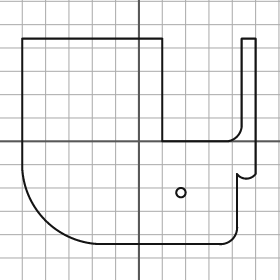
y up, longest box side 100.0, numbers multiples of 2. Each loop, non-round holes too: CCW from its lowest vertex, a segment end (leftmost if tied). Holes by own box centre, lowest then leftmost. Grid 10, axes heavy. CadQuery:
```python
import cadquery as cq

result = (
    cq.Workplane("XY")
    .moveTo(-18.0, -44.0)
    .lineTo(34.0, -44.0)
    .threePointArc((40.0, -42.0), (42.0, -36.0))
    .lineTo(42.0, -14.0)
    .threePointArc((46.0, -16.0), (50.0, -14.0))
    .lineTo(50.0, 44.0)
    .lineTo(44.0, 44.0)
    .lineTo(44.0, 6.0)
    .threePointArc((42.0, 2.0), (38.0, 0.0))
    .lineTo(10.0, 0.0)
    .lineTo(10.0, 44.0)
    .lineTo(-50.0, 44.0)
    .lineTo(-50.0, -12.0)
    .threePointArc((-40.0, -34.0), (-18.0, -44.0))
    .close()
    .moveTo(18.0, -22.0)
    .circle(2.0)
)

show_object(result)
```